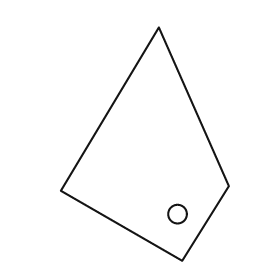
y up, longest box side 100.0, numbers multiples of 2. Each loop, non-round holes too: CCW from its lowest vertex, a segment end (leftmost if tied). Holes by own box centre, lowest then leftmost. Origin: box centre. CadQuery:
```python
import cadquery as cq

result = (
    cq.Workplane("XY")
    .moveTo(16.0, -50.0)
    .lineTo(36.0, -18.0)
    .lineTo(6.0, 50.0)
    .lineTo(-36.0, -20.0)
    .close()
    .moveTo(14.0, -30.0)
    .circle(4.0)
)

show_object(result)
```